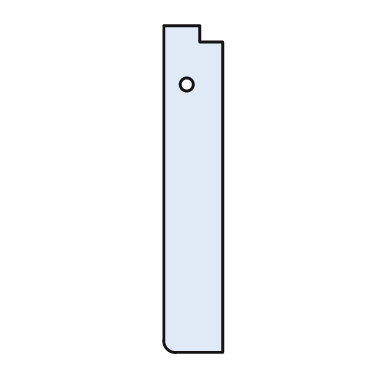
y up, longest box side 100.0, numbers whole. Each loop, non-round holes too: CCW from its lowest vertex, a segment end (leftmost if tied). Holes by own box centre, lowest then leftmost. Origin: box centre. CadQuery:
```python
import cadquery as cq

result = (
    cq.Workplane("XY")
    .moveTo(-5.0, -50.0)
    .lineTo(9.0, -50.0)
    .lineTo(9.0, 45.0)
    .lineTo(2.0, 45.0)
    .lineTo(2.0, 50.0)
    .lineTo(-9.0, 50.0)
    .lineTo(-9.0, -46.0)
    .threePointArc((-8.0, -49.0), (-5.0, -50.0))
    .close()
    .moveTo(-2.0, 32.0)
    .circle(2.0)
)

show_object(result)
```